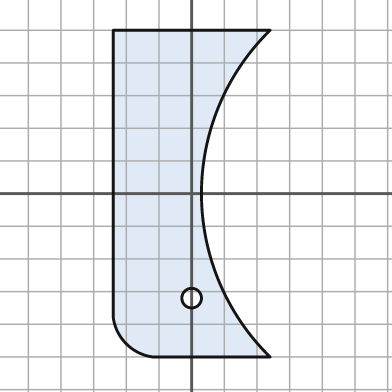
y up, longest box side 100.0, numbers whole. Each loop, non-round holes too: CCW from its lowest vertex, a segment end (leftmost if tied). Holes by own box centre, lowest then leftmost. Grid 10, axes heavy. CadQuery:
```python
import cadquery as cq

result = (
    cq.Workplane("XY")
    .moveTo(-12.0, -50.0)
    .lineTo(24.0, -50.0)
    .threePointArc((3.0, 0.0), (24.0, 50.0))
    .lineTo(-24.0, 50.0)
    .lineTo(-24.0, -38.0)
    .threePointArc((-20.0, -46.0), (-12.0, -50.0))
    .close()
    .moveTo(0.0, -32.0)
    .circle(3.0)
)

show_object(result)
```